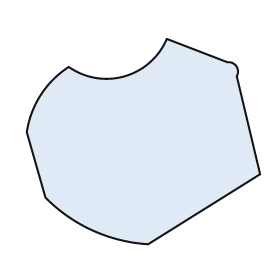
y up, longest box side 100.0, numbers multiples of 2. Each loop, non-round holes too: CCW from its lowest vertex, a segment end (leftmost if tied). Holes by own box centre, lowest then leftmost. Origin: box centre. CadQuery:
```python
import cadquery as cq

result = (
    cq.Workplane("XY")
    .moveTo(2.0, -44.0)
    .lineTo(50.0, -14.0)
    .lineTo(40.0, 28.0)
    .threePointArc((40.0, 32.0), (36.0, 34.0))
    .lineTo(10.0, 44.0)
    .threePointArc((-8.0, 28.0), (-32.0, 32.0))
    .threePointArc((-44.0, 20.0), (-50.0, 4.0))
    .lineTo(-42.0, -24.0)
    .threePointArc((-22.0, -38.0), (2.0, -44.0))
    .close()
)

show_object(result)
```